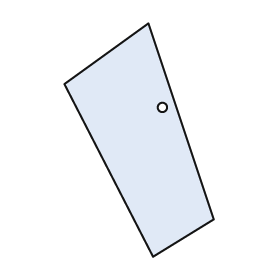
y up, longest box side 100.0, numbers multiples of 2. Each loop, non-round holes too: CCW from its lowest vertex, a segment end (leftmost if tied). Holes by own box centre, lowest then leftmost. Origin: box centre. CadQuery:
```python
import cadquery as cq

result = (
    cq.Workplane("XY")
    .moveTo(6.0, -50.0)
    .lineTo(32.0, -34.0)
    .lineTo(4.0, 50.0)
    .lineTo(-32.0, 24.0)
    .close()
    .moveTo(10.0, 14.0)
    .circle(2.0)
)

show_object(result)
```